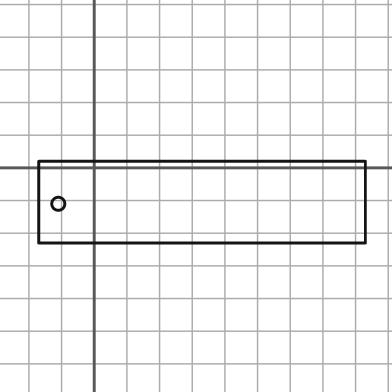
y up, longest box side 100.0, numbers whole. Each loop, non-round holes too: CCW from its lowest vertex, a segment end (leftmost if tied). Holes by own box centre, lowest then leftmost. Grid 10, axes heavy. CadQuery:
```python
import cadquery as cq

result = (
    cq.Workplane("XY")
    .moveTo(-17.0, -23.0)
    .lineTo(83.0, -23.0)
    .lineTo(83.0, 2.0)
    .lineTo(-17.0, 2.0)
    .close()
    .moveTo(-11.0, -11.0)
    .circle(2.0)
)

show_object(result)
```